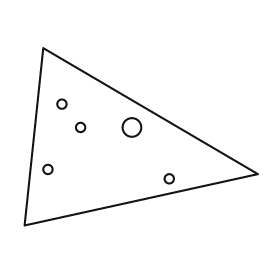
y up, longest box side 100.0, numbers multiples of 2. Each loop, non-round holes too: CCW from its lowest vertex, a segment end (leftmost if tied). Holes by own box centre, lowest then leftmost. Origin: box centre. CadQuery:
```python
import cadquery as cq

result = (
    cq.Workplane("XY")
    .moveTo(-50.0, -38.0)
    .lineTo(50.0, -16.0)
    .lineTo(-42.0, 38.0)
    .close()
    .moveTo(12.0, -18.0)
    .circle(2.0)
    .moveTo(-40.0, -14.0)
    .circle(2.0)
    .moveTo(-26.0, 4.0)
    .circle(2.0)
    .moveTo(-4.0, 4.0)
    .circle(4.0)
    .moveTo(-34.0, 14.0)
    .circle(2.0)
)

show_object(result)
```